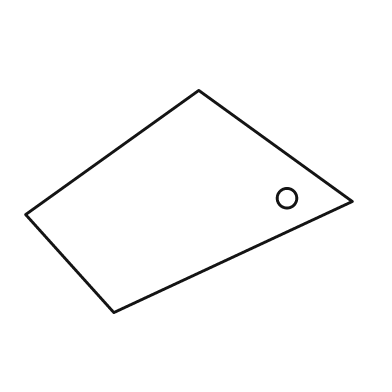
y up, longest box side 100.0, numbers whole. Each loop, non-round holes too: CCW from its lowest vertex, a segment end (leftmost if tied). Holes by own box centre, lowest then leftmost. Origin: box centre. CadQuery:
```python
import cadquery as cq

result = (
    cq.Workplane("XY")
    .moveTo(-23.0, -34.0)
    .lineTo(50.0, 0.0)
    .lineTo(3.0, 34.0)
    .lineTo(-50.0, -4.0)
    .close()
    .moveTo(30.0, 1.0)
    .circle(3.0)
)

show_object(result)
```